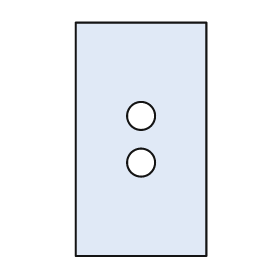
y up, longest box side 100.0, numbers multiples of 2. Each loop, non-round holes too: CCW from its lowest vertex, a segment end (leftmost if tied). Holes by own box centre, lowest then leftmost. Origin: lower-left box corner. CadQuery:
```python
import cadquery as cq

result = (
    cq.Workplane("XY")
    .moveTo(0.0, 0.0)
    .lineTo(56.0, 0.0)
    .lineTo(56.0, 100.0)
    .lineTo(0.0, 100.0)
    .close()
    .moveTo(28.0, 40.0)
    .circle(6.0)
    .moveTo(28.0, 60.0)
    .circle(6.0)
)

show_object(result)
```